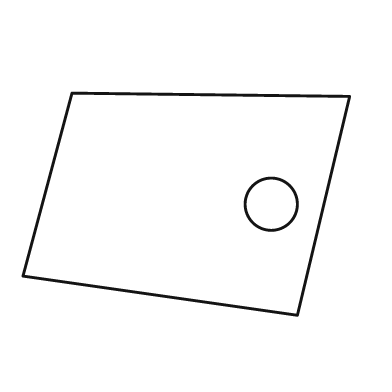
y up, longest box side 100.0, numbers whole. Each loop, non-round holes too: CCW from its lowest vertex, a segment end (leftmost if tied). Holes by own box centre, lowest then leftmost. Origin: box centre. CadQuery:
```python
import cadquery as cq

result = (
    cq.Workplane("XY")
    .moveTo(34.0, -34.0)
    .lineTo(50.0, 33.0)
    .lineTo(-35.0, 34.0)
    .lineTo(-50.0, -22.0)
    .close()
    .moveTo(26.0, 0.0)
    .circle(8.0)
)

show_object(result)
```